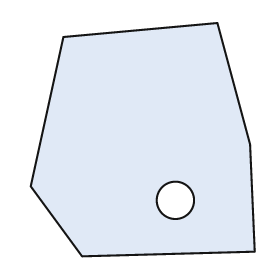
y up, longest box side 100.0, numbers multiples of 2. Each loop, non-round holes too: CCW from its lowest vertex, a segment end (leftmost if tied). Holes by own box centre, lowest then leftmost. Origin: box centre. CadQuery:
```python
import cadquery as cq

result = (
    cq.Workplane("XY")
    .moveTo(-26.0, -50.0)
    .lineTo(48.0, -48.0)
    .lineTo(46.0, -2.0)
    .lineTo(32.0, 50.0)
    .lineTo(-34.0, 44.0)
    .lineTo(-48.0, -20.0)
    .close()
    .moveTo(14.0, -26.0)
    .circle(8.0)
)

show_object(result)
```